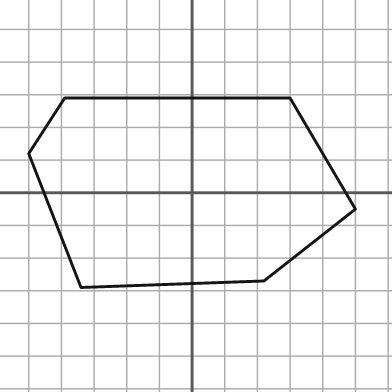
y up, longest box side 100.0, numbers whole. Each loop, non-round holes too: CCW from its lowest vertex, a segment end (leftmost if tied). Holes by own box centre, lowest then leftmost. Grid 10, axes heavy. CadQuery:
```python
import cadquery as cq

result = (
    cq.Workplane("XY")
    .moveTo(-34.0, -29.0)
    .lineTo(22.0, -27.0)
    .lineTo(50.0, -5.0)
    .lineTo(30.0, 29.0)
    .lineTo(-39.0, 29.0)
    .lineTo(-50.0, 12.0)
    .close()
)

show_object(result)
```